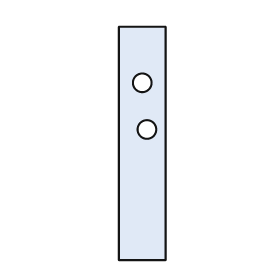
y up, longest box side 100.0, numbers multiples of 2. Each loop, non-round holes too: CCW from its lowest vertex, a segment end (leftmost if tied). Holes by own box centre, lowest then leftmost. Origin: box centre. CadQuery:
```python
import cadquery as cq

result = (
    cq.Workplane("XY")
    .moveTo(-10.0, -50.0)
    .lineTo(10.0, -50.0)
    .lineTo(10.0, 50.0)
    .lineTo(-10.0, 50.0)
    .close()
    .moveTo(2.0, 6.0)
    .circle(4.0)
    .moveTo(0.0, 26.0)
    .circle(4.0)
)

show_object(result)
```